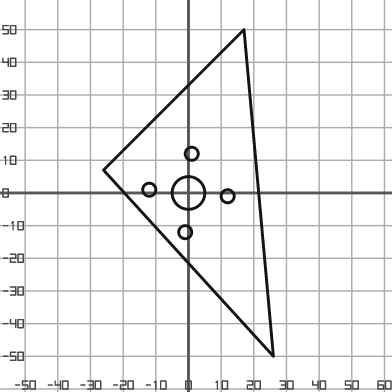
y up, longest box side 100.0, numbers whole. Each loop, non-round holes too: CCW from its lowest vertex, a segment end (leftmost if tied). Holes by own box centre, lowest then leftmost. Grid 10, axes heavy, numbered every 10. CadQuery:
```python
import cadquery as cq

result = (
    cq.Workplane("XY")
    .moveTo(26.0, -50.0)
    .lineTo(17.0, 50.0)
    .lineTo(-26.0, 7.0)
    .close()
    .moveTo(-1.0, -12.0)
    .circle(2.0)
    .moveTo(12.0, -1.0)
    .circle(2.0)
    .moveTo(0.0, 0.0)
    .circle(5.0)
    .moveTo(-12.0, 1.0)
    .circle(2.0)
    .moveTo(1.0, 12.0)
    .circle(2.0)
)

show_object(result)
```